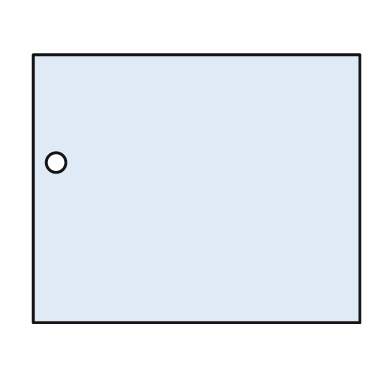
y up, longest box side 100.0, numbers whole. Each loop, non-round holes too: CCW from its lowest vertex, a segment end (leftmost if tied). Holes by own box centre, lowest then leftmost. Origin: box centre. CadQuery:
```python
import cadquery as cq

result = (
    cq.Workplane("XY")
    .moveTo(-50.0, -41.0)
    .lineTo(50.0, -41.0)
    .lineTo(50.0, 41.0)
    .lineTo(-50.0, 41.0)
    .close()
    .moveTo(-43.0, 8.0)
    .circle(3.0)
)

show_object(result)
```